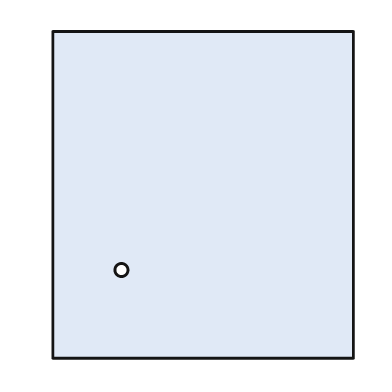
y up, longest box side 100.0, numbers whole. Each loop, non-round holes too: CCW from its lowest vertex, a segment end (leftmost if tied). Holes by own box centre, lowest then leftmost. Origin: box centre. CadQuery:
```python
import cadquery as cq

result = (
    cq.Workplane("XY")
    .moveTo(-46.0, -50.0)
    .lineTo(46.0, -50.0)
    .lineTo(46.0, 50.0)
    .lineTo(-46.0, 50.0)
    .close()
    .moveTo(-25.0, -23.0)
    .circle(2.0)
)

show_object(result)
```